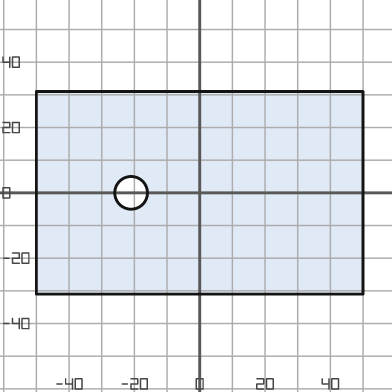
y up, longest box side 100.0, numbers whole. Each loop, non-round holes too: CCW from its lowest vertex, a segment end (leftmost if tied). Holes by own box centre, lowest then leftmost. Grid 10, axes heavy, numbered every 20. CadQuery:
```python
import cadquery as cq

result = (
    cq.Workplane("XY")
    .moveTo(-50.0, -31.0)
    .lineTo(50.0, -31.0)
    .lineTo(50.0, 31.0)
    .lineTo(-50.0, 31.0)
    .close()
    .moveTo(-21.0, 0.0)
    .circle(5.0)
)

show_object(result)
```